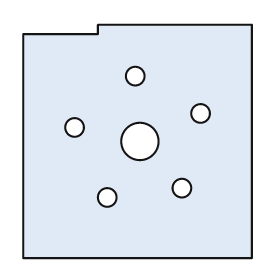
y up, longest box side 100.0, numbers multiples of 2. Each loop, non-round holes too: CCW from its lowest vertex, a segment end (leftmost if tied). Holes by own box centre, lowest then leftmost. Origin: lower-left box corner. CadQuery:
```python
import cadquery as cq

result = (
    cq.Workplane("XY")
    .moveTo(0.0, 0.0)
    .lineTo(98.0, 0.0)
    .lineTo(98.0, 100.0)
    .lineTo(32.0, 100.0)
    .lineTo(32.0, 96.0)
    .lineTo(0.0, 96.0)
    .close()
    .moveTo(36.0, 26.0)
    .circle(4.0)
    .moveTo(68.0, 30.0)
    .circle(4.0)
    .moveTo(50.0, 50.0)
    .circle(8.0)
    .moveTo(22.0, 56.0)
    .circle(4.0)
    .moveTo(76.0, 62.0)
    .circle(4.0)
    .moveTo(48.0, 78.0)
    .circle(4.0)
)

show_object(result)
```